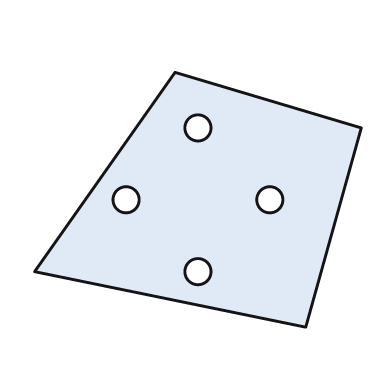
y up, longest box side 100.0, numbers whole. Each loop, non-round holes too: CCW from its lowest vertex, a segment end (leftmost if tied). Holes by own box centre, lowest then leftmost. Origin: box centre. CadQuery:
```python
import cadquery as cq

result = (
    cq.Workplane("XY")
    .moveTo(33.0, -39.0)
    .lineTo(50.0, 22.0)
    .lineTo(-7.0, 39.0)
    .lineTo(-50.0, -22.0)
    .close()
    .moveTo(0.0, -22.0)
    .circle(4.0)
    .moveTo(-22.0, 0.0)
    .circle(4.0)
    .moveTo(22.0, 0.0)
    .circle(4.0)
    .moveTo(0.0, 22.0)
    .circle(4.0)
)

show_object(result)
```